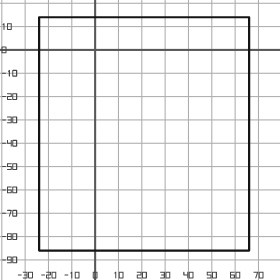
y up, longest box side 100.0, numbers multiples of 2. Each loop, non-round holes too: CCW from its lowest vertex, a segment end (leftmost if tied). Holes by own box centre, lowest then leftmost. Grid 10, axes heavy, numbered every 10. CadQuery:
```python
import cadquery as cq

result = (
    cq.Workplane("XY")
    .moveTo(-24.0, -86.0)
    .lineTo(66.0, -86.0)
    .lineTo(66.0, 14.0)
    .lineTo(-24.0, 14.0)
    .close()
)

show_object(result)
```